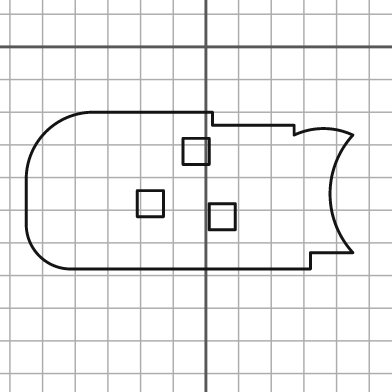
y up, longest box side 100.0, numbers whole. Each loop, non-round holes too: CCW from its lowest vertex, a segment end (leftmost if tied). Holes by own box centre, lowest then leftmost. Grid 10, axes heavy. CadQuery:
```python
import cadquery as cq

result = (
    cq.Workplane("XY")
    .moveTo(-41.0, -68.0)
    .lineTo(32.0, -68.0)
    .lineTo(32.0, -63.0)
    .lineTo(45.0, -63.0)
    .threePointArc((38.0, -45.0), (45.0, -27.0))
    .threePointArc((36.0, -25.0), (27.0, -27.0))
    .lineTo(27.0, -24.0)
    .lineTo(2.0, -24.0)
    .lineTo(2.0, -20.0)
    .lineTo(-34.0, -20.0)
    .threePointArc((-49.0, -26.0), (-55.0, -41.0))
    .lineTo(-55.0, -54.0)
    .threePointArc((-51.0, -64.0), (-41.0, -68.0))
    .close()
    .moveTo(1.0, -56.0)
    .lineTo(9.0, -56.0)
    .lineTo(9.0, -48.0)
    .lineTo(1.0, -48.0)
    .close()
    .moveTo(-21.0, -52.0)
    .lineTo(-13.0, -52.0)
    .lineTo(-13.0, -44.0)
    .lineTo(-21.0, -44.0)
    .close()
    .moveTo(-7.0, -36.0)
    .lineTo(1.0, -36.0)
    .lineTo(1.0, -28.0)
    .lineTo(-7.0, -28.0)
    .close()
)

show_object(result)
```